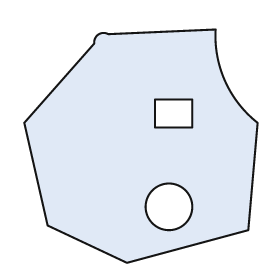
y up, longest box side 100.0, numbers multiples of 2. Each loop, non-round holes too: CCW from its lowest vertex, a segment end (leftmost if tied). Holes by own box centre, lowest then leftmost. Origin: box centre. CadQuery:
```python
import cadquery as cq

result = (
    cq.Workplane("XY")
    .moveTo(-6.0, -50.0)
    .lineTo(46.0, -36.0)
    .lineTo(50.0, 10.0)
    .threePointArc((36.0, 28.0), (32.0, 50.0))
    .lineTo(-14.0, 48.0)
    .threePointArc((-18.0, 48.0), (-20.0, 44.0))
    .lineTo(-50.0, 10.0)
    .lineTo(-40.0, -34.0)
    .close()
    .moveTo(12.0, -26.0)
    .circle(10.0)
    .moveTo(6.0, 8.0)
    .lineTo(22.0, 8.0)
    .lineTo(22.0, 20.0)
    .lineTo(6.0, 20.0)
    .close()
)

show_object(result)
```